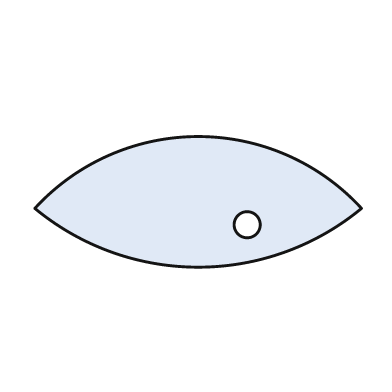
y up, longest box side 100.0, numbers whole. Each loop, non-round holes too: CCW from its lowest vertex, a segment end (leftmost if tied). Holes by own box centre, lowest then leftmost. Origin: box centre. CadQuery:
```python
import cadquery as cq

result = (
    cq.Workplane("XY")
    .moveTo(-50.0, -2.0)
    .threePointArc((0.0, -20.0), (50.0, -2.0))
    .threePointArc((0.0, 20.0), (-50.0, -2.0))
    .close()
    .moveTo(15.0, -7.0)
    .circle(4.0)
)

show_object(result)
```